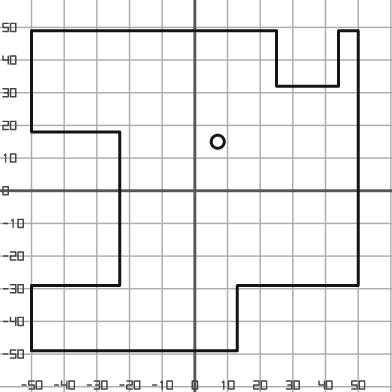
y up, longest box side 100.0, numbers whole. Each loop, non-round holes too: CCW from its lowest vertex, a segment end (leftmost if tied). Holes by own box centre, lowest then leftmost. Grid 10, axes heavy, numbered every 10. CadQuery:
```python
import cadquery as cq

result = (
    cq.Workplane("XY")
    .moveTo(-50.0, -49.0)
    .lineTo(13.0, -49.0)
    .lineTo(13.0, -29.0)
    .lineTo(50.0, -29.0)
    .lineTo(50.0, 49.0)
    .lineTo(44.0, 49.0)
    .lineTo(44.0, 32.0)
    .lineTo(25.0, 32.0)
    .lineTo(25.0, 49.0)
    .lineTo(-50.0, 49.0)
    .lineTo(-50.0, 18.0)
    .lineTo(-23.0, 18.0)
    .lineTo(-23.0, -29.0)
    .lineTo(-50.0, -29.0)
    .close()
    .moveTo(7.0, 15.0)
    .circle(2.0)
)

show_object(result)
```